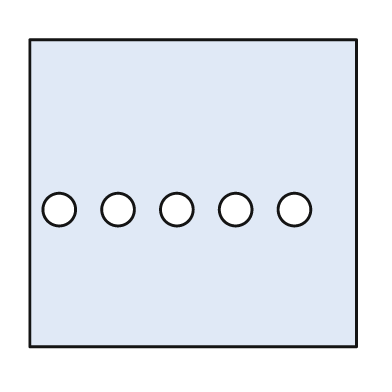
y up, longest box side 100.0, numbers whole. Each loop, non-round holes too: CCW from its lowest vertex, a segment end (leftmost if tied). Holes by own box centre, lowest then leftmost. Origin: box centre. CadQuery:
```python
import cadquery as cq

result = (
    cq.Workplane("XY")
    .moveTo(-50.0, -47.0)
    .lineTo(50.0, -47.0)
    .lineTo(50.0, 47.0)
    .lineTo(-50.0, 47.0)
    .close()
    .moveTo(-41.0, -5.0)
    .circle(5.0)
    .moveTo(-23.0, -5.0)
    .circle(5.0)
    .moveTo(-5.0, -5.0)
    .circle(5.0)
    .moveTo(13.0, -5.0)
    .circle(5.0)
    .moveTo(31.0, -5.0)
    .circle(5.0)
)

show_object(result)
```